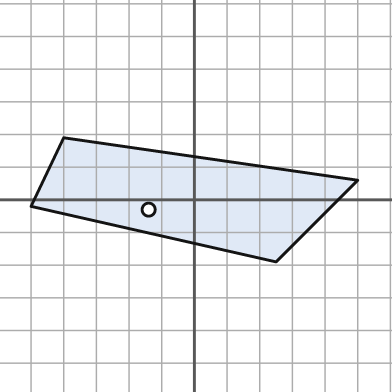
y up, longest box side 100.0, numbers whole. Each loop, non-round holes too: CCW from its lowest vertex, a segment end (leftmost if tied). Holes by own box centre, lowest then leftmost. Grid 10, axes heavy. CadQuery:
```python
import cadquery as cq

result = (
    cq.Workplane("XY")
    .moveTo(25.0, -19.0)
    .lineTo(50.0, 6.0)
    .lineTo(-40.0, 19.0)
    .lineTo(-50.0, -2.0)
    .close()
    .moveTo(-14.0, -3.0)
    .circle(2.0)
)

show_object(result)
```